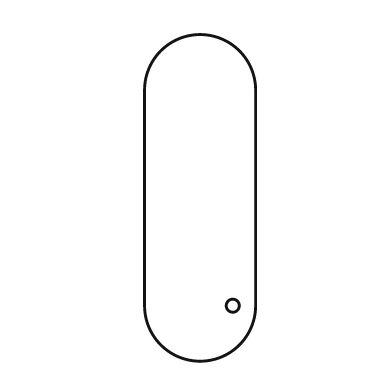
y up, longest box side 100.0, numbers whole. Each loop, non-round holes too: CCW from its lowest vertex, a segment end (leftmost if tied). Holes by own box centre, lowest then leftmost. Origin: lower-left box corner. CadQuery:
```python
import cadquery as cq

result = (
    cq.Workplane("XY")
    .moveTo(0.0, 17.0)
    .threePointArc((17.0, 0.0), (34.0, 17.0))
    .lineTo(34.0, 83.0)
    .threePointArc((17.0, 100.0), (0.0, 83.0))
    .close()
    .moveTo(27.0, 17.0)
    .circle(2.0)
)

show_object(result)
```